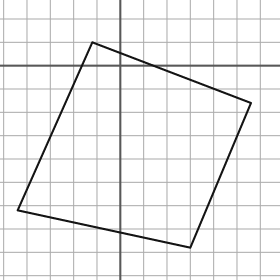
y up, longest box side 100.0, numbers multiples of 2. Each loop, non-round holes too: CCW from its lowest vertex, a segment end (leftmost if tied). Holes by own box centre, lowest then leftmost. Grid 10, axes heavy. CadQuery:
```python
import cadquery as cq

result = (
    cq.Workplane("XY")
    .moveTo(30.0, -78.0)
    .lineTo(56.0, -16.0)
    .lineTo(-12.0, 10.0)
    .lineTo(-44.0, -62.0)
    .close()
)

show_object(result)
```